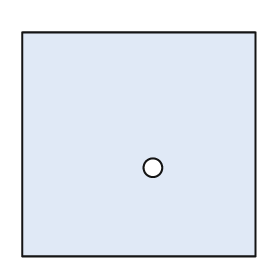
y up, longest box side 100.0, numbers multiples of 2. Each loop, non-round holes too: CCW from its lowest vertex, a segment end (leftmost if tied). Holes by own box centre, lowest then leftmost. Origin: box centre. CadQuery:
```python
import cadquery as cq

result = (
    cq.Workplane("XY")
    .moveTo(-50.0, -48.0)
    .lineTo(50.0, -48.0)
    .lineTo(50.0, 48.0)
    .lineTo(-50.0, 48.0)
    .close()
    .moveTo(6.0, -10.0)
    .circle(4.0)
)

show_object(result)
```